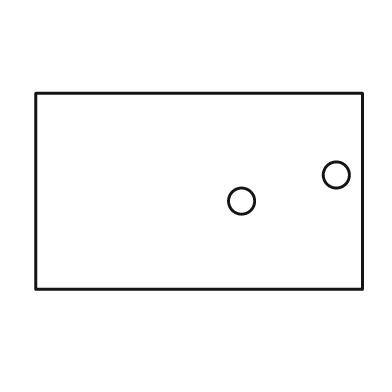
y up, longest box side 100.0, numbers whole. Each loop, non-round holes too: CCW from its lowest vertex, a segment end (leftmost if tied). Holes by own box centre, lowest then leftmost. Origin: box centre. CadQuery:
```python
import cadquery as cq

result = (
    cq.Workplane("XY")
    .moveTo(-50.0, -30.0)
    .lineTo(50.0, -30.0)
    .lineTo(50.0, 30.0)
    .lineTo(-50.0, 30.0)
    .close()
    .moveTo(13.0, -3.0)
    .circle(4.0)
    .moveTo(42.0, 5.0)
    .circle(4.0)
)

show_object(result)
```